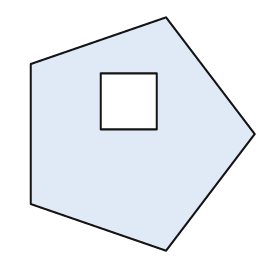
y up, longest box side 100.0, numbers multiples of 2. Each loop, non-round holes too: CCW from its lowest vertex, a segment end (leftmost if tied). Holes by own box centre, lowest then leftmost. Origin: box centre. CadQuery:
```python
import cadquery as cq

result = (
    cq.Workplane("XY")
    .moveTo(10.0, -50.0)
    .lineTo(48.0, 0.0)
    .lineTo(10.0, 50.0)
    .lineTo(-48.0, 30.0)
    .lineTo(-48.0, -30.0)
    .close()
    .moveTo(-18.0, 2.0)
    .lineTo(6.0, 2.0)
    .lineTo(6.0, 26.0)
    .lineTo(-18.0, 26.0)
    .close()
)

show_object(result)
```